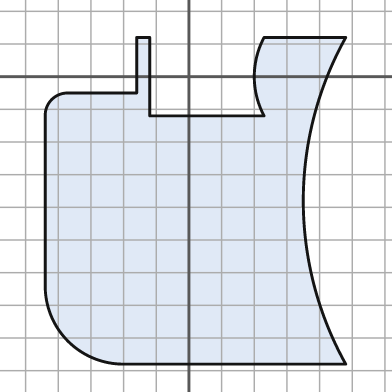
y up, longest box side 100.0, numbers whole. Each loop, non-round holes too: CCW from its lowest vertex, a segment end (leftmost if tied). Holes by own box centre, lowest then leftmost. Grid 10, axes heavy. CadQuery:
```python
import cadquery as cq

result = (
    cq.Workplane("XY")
    .moveTo(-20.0, -88.0)
    .lineTo(48.0, -88.0)
    .threePointArc((35.0, -38.0), (48.0, 12.0))
    .lineTo(23.0, 12.0)
    .threePointArc((20.0, 0.0), (23.0, -12.0))
    .lineTo(-12.0, -12.0)
    .lineTo(-12.0, 12.0)
    .lineTo(-16.0, 12.0)
    .lineTo(-16.0, -5.0)
    .lineTo(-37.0, -5.0)
    .threePointArc((-42.0, -7.0), (-44.0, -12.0))
    .lineTo(-44.0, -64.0)
    .threePointArc((-37.0, -81.0), (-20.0, -88.0))
    .close()
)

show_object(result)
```